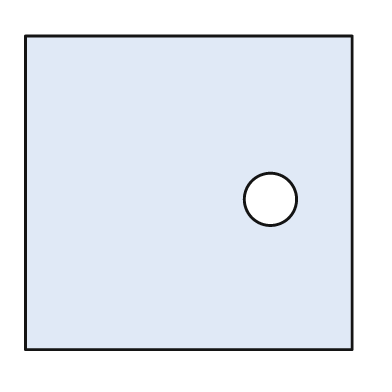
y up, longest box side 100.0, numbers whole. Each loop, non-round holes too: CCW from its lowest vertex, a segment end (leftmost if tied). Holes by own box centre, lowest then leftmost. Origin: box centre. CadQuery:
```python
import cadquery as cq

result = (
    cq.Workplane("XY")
    .moveTo(-50.0, -48.0)
    .lineTo(50.0, -48.0)
    .lineTo(50.0, 48.0)
    .lineTo(-50.0, 48.0)
    .close()
    .moveTo(25.0, -2.0)
    .circle(8.0)
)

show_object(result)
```